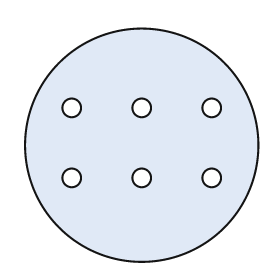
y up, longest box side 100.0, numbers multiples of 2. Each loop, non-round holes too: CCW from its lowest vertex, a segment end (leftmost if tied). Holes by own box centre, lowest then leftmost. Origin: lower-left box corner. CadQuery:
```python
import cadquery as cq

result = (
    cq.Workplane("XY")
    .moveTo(50.0, 50.0)
    .circle(50.0)
    .moveTo(20.0, 36.0)
    .circle(4.0)
    .moveTo(50.0, 36.0)
    .circle(4.0)
    .moveTo(80.0, 36.0)
    .circle(4.0)
    .moveTo(20.0, 66.0)
    .circle(4.0)
    .moveTo(50.0, 66.0)
    .circle(4.0)
    .moveTo(80.0, 66.0)
    .circle(4.0)
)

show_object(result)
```